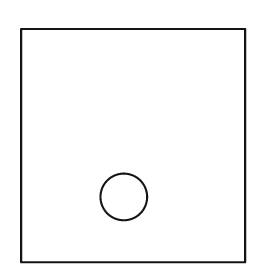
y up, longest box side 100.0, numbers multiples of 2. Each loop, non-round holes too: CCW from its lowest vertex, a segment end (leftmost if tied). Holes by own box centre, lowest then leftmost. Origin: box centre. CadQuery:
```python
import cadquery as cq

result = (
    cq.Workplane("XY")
    .moveTo(-48.0, -50.0)
    .lineTo(48.0, -50.0)
    .lineTo(48.0, 50.0)
    .lineTo(-48.0, 50.0)
    .close()
    .moveTo(-4.0, -22.0)
    .circle(10.0)
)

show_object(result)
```